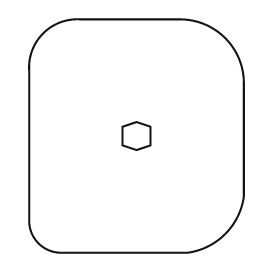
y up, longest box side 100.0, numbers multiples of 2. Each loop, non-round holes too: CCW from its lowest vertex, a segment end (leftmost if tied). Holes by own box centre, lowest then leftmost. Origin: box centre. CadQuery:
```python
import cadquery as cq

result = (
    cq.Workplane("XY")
    .moveTo(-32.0, -50.0)
    .lineTo(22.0, -50.0)
    .threePointArc((38.0, -42.0), (46.0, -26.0))
    .lineTo(46.0, 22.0)
    .threePointArc((38.0, 42.0), (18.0, 50.0))
    .lineTo(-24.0, 50.0)
    .threePointArc((-40.0, 44.0), (-46.0, 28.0))
    .lineTo(-46.0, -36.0)
    .threePointArc((-42.0, -46.0), (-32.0, -50.0))
    .close()
    .moveTo(0.0, -6.0)
    .lineTo(6.0, -4.0)
    .lineTo(6.0, 4.0)
    .lineTo(0.0, 6.0)
    .lineTo(-6.0, 4.0)
    .lineTo(-6.0, -4.0)
    .close()
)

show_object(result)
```